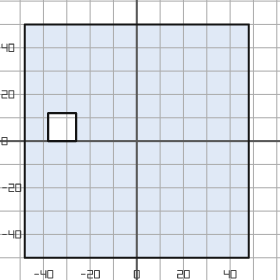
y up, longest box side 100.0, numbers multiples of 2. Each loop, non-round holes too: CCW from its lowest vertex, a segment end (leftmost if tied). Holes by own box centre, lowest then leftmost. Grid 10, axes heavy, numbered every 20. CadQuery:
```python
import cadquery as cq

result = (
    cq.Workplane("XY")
    .moveTo(-48.0, -50.0)
    .lineTo(48.0, -50.0)
    .lineTo(48.0, 50.0)
    .lineTo(-48.0, 50.0)
    .close()
    .moveTo(-38.0, 0.0)
    .lineTo(-26.0, 0.0)
    .lineTo(-26.0, 12.0)
    .lineTo(-38.0, 12.0)
    .close()
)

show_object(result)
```